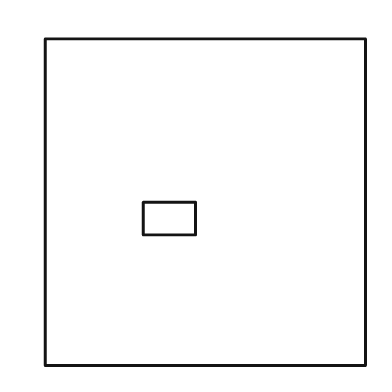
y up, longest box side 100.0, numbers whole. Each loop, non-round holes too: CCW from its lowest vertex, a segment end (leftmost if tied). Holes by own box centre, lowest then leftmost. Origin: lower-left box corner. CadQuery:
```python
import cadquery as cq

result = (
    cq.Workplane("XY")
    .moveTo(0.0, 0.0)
    .lineTo(98.0, 0.0)
    .lineTo(98.0, 100.0)
    .lineTo(0.0, 100.0)
    .close()
    .moveTo(30.0, 40.0)
    .lineTo(46.0, 40.0)
    .lineTo(46.0, 50.0)
    .lineTo(30.0, 50.0)
    .close()
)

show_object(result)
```